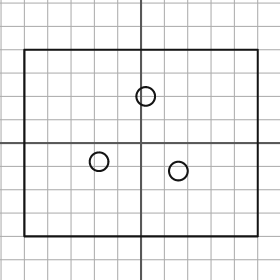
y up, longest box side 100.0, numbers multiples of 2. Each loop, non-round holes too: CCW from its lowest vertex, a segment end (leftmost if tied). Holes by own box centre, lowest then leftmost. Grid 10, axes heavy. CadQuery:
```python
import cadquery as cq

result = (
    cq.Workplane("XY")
    .moveTo(-50.0, -40.0)
    .lineTo(50.0, -40.0)
    .lineTo(50.0, 40.0)
    .lineTo(-50.0, 40.0)
    .close()
    .moveTo(16.0, -12.0)
    .circle(4.0)
    .moveTo(-18.0, -8.0)
    .circle(4.0)
    .moveTo(2.0, 20.0)
    .circle(4.0)
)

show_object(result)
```